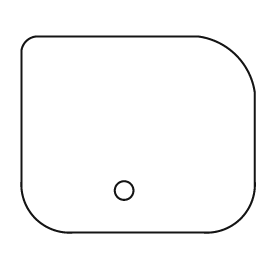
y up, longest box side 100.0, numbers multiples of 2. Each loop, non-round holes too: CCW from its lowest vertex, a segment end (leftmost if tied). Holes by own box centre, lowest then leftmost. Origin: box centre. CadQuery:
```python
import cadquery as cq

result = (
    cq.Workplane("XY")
    .moveTo(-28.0, -42.0)
    .lineTo(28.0, -42.0)
    .threePointArc((44.0, -36.0), (50.0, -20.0))
    .lineTo(50.0, 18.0)
    .threePointArc((42.0, 34.0), (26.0, 42.0))
    .lineTo(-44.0, 42.0)
    .threePointArc((-48.0, 40.0), (-50.0, 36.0))
    .lineTo(-50.0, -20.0)
    .threePointArc((-44.0, -36.0), (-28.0, -42.0))
    .close()
    .moveTo(-6.0, -24.0)
    .circle(4.0)
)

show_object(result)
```